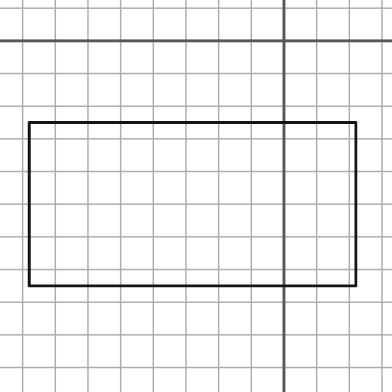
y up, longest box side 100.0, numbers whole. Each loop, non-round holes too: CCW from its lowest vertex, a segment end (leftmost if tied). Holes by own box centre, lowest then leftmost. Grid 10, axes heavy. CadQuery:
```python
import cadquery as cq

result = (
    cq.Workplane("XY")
    .moveTo(-78.0, -75.0)
    .lineTo(22.0, -75.0)
    .lineTo(22.0, -25.0)
    .lineTo(-78.0, -25.0)
    .close()
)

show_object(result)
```